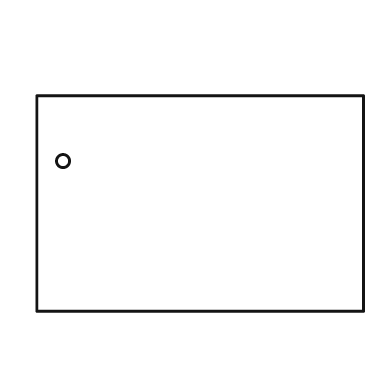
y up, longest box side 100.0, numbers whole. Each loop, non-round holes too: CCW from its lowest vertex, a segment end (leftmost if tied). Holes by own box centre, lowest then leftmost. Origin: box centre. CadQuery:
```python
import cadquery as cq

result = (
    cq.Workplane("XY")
    .moveTo(-50.0, -33.0)
    .lineTo(50.0, -33.0)
    .lineTo(50.0, 33.0)
    .lineTo(-50.0, 33.0)
    .close()
    .moveTo(-42.0, 13.0)
    .circle(2.0)
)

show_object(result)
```